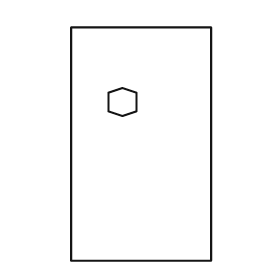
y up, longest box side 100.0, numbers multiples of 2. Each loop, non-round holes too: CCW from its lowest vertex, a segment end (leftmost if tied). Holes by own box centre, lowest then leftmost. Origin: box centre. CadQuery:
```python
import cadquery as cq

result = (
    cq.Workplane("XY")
    .moveTo(-30.0, -50.0)
    .lineTo(30.0, -50.0)
    .lineTo(30.0, 50.0)
    .lineTo(-30.0, 50.0)
    .close()
    .moveTo(-8.0, 12.0)
    .lineTo(-2.0, 14.0)
    .lineTo(-2.0, 22.0)
    .lineTo(-8.0, 24.0)
    .lineTo(-14.0, 22.0)
    .lineTo(-14.0, 14.0)
    .close()
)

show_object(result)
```